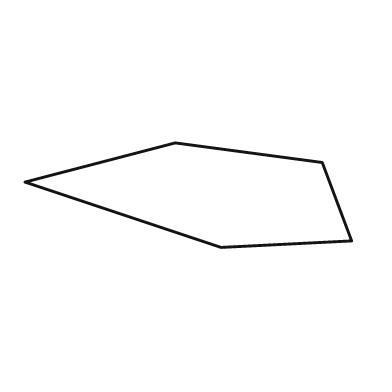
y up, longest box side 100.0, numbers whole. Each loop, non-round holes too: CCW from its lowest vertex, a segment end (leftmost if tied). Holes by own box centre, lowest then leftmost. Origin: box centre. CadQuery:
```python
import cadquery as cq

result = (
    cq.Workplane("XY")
    .moveTo(10.0, -16.0)
    .lineTo(50.0, -14.0)
    .lineTo(41.0, 10.0)
    .lineTo(-4.0, 16.0)
    .lineTo(-50.0, 4.0)
    .close()
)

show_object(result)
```